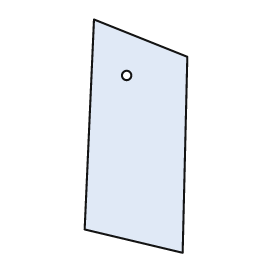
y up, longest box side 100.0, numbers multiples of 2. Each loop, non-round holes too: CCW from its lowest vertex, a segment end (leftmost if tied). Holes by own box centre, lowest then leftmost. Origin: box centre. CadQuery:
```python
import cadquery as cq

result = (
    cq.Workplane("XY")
    .moveTo(20.0, -50.0)
    .lineTo(22.0, 34.0)
    .lineTo(-18.0, 50.0)
    .lineTo(-22.0, -40.0)
    .close()
    .moveTo(-4.0, 26.0)
    .circle(2.0)
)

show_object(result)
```